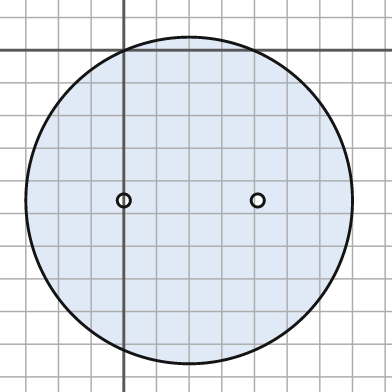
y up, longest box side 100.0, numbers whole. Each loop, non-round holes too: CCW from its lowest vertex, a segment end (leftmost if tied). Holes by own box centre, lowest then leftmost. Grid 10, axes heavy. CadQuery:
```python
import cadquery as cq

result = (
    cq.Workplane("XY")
    .moveTo(20.0, -46.0)
    .circle(50.0)
    .moveTo(0.0, -46.0)
    .circle(2.0)
    .moveTo(41.0, -46.0)
    .circle(2.0)
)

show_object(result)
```